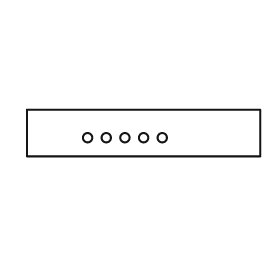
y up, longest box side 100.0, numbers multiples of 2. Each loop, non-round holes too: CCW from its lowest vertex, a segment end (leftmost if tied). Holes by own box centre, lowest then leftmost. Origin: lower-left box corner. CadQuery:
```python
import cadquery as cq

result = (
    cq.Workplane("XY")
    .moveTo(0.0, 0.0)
    .lineTo(100.0, 0.0)
    .lineTo(100.0, 20.0)
    .lineTo(0.0, 20.0)
    .close()
    .moveTo(26.0, 8.0)
    .circle(2.0)
    .moveTo(34.0, 8.0)
    .circle(2.0)
    .moveTo(42.0, 8.0)
    .circle(2.0)
    .moveTo(50.0, 8.0)
    .circle(2.0)
    .moveTo(58.0, 8.0)
    .circle(2.0)
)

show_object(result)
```